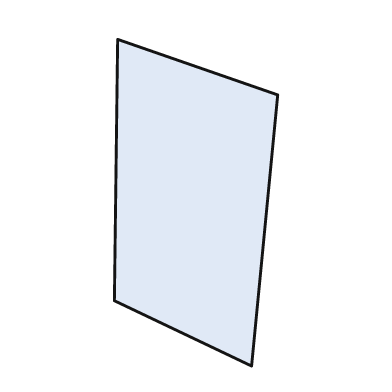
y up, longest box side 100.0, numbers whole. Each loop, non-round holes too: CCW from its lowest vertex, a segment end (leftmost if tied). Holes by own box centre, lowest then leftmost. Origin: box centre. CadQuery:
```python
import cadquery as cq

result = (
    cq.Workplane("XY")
    .moveTo(17.0, -50.0)
    .lineTo(25.0, 33.0)
    .lineTo(-24.0, 50.0)
    .lineTo(-25.0, -30.0)
    .close()
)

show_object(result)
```